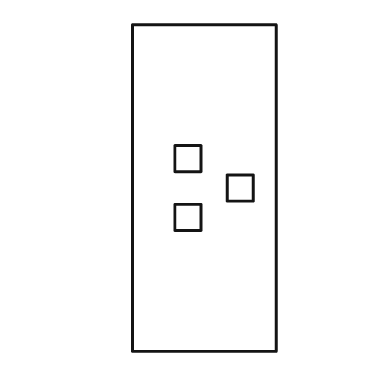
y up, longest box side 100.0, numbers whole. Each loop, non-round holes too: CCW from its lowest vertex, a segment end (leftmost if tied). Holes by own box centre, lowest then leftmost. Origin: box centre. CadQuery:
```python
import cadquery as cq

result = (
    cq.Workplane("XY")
    .moveTo(-22.0, -50.0)
    .lineTo(22.0, -50.0)
    .lineTo(22.0, 50.0)
    .lineTo(-22.0, 50.0)
    .close()
    .moveTo(-9.0, -13.0)
    .lineTo(-1.0, -13.0)
    .lineTo(-1.0, -5.0)
    .lineTo(-9.0, -5.0)
    .close()
    .moveTo(7.0, -4.0)
    .lineTo(15.0, -4.0)
    .lineTo(15.0, 4.0)
    .lineTo(7.0, 4.0)
    .close()
    .moveTo(-9.0, 5.0)
    .lineTo(-1.0, 5.0)
    .lineTo(-1.0, 13.0)
    .lineTo(-9.0, 13.0)
    .close()
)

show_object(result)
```